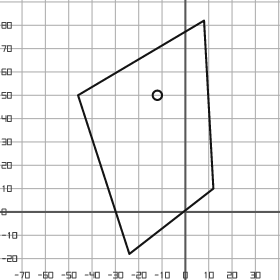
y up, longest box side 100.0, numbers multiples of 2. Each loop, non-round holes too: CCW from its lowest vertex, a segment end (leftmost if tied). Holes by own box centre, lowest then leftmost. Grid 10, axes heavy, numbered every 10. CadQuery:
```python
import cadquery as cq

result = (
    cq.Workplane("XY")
    .moveTo(-24.0, -18.0)
    .lineTo(12.0, 10.0)
    .lineTo(8.0, 82.0)
    .lineTo(-46.0, 50.0)
    .close()
    .moveTo(-12.0, 50.0)
    .circle(2.0)
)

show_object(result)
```